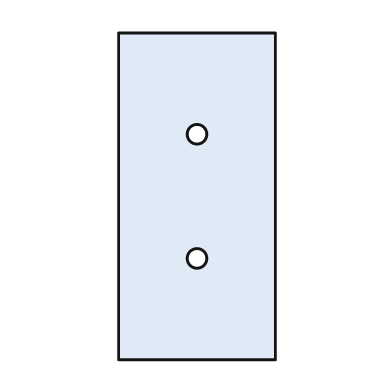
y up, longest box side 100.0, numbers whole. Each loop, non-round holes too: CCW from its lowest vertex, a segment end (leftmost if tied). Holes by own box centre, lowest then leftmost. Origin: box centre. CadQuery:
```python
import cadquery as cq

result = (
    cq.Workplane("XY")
    .moveTo(-24.0, -50.0)
    .lineTo(24.0, -50.0)
    .lineTo(24.0, 50.0)
    .lineTo(-24.0, 50.0)
    .close()
    .moveTo(0.0, -19.0)
    .circle(3.0)
    .moveTo(0.0, 19.0)
    .circle(3.0)
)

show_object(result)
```